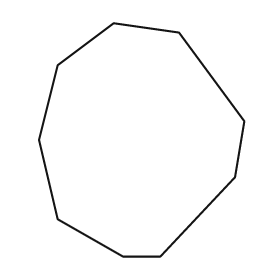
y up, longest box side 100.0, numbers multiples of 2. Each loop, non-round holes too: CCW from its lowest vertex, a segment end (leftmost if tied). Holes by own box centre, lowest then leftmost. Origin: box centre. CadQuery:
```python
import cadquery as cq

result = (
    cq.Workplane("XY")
    .moveTo(-8.0, -50.0)
    .lineTo(8.0, -50.0)
    .lineTo(40.0, -16.0)
    .lineTo(44.0, 8.0)
    .lineTo(16.0, 46.0)
    .lineTo(-12.0, 50.0)
    .lineTo(-36.0, 32.0)
    .lineTo(-44.0, 0.0)
    .lineTo(-36.0, -34.0)
    .close()
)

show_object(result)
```